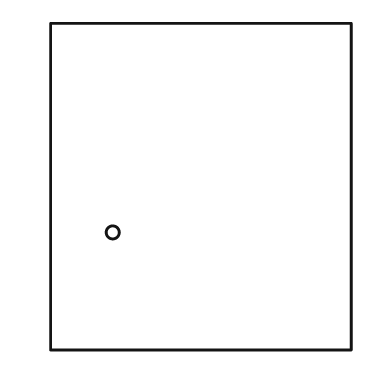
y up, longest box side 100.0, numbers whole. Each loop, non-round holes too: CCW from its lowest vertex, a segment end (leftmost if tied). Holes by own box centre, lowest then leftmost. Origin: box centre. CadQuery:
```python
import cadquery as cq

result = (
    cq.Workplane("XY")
    .moveTo(-46.0, -50.0)
    .lineTo(46.0, -50.0)
    .lineTo(46.0, 50.0)
    .lineTo(-46.0, 50.0)
    .close()
    .moveTo(-27.0, -14.0)
    .circle(2.0)
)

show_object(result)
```